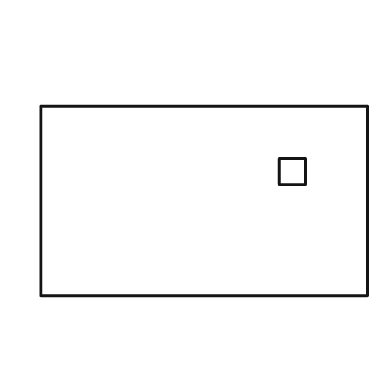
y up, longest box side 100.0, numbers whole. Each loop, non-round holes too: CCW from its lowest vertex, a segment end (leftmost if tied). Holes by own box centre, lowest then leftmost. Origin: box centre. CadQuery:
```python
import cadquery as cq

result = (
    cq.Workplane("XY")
    .moveTo(-50.0, -29.0)
    .lineTo(50.0, -29.0)
    .lineTo(50.0, 29.0)
    .lineTo(-50.0, 29.0)
    .close()
    .moveTo(23.0, 5.0)
    .lineTo(31.0, 5.0)
    .lineTo(31.0, 13.0)
    .lineTo(23.0, 13.0)
    .close()
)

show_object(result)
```